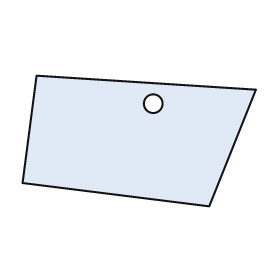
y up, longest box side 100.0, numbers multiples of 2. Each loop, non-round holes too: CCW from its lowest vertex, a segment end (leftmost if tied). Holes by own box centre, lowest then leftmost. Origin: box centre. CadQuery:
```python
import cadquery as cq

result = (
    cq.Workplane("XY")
    .moveTo(30.0, -28.0)
    .lineTo(50.0, 22.0)
    .lineTo(-44.0, 28.0)
    .lineTo(-50.0, -18.0)
    .close()
    .moveTo(6.0, 16.0)
    .circle(4.0)
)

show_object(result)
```